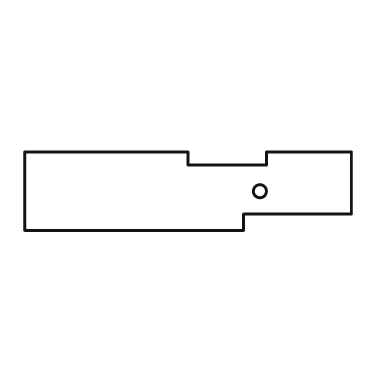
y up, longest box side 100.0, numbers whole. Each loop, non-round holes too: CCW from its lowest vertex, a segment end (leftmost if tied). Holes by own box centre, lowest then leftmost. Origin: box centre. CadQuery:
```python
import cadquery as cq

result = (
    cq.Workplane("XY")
    .moveTo(-50.0, -12.0)
    .lineTo(17.0, -12.0)
    .lineTo(17.0, -7.0)
    .lineTo(50.0, -7.0)
    .lineTo(50.0, 12.0)
    .lineTo(24.0, 12.0)
    .lineTo(24.0, 8.0)
    .lineTo(0.0, 8.0)
    .lineTo(0.0, 12.0)
    .lineTo(-50.0, 12.0)
    .close()
    .moveTo(22.0, 0.0)
    .circle(2.0)
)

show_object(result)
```